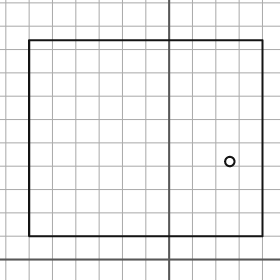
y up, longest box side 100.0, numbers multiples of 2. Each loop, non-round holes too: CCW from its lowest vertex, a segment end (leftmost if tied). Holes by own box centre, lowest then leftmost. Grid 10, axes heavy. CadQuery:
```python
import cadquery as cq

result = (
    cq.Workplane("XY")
    .moveTo(-60.0, 10.0)
    .lineTo(40.0, 10.0)
    .lineTo(40.0, 94.0)
    .lineTo(-60.0, 94.0)
    .close()
    .moveTo(26.0, 42.0)
    .circle(2.0)
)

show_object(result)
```